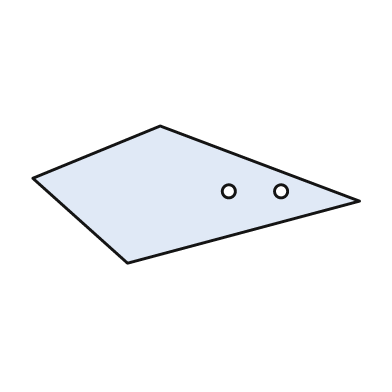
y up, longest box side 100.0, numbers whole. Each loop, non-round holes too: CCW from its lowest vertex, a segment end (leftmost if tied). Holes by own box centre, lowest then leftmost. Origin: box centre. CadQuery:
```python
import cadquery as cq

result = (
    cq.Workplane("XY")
    .moveTo(-21.0, -21.0)
    .lineTo(50.0, -2.0)
    .lineTo(-11.0, 21.0)
    .lineTo(-50.0, 5.0)
    .close()
    .moveTo(10.0, 1.0)
    .circle(2.0)
    .moveTo(26.0, 1.0)
    .circle(2.0)
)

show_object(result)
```